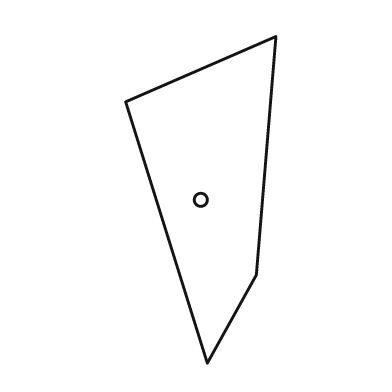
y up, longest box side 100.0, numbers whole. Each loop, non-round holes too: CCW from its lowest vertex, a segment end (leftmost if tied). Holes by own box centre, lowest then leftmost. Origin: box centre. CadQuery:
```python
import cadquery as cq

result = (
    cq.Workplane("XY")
    .moveTo(2.0, -50.0)
    .lineTo(17.0, -23.0)
    .lineTo(23.0, 50.0)
    .lineTo(-23.0, 30.0)
    .close()
    .moveTo(0.0, 0.0)
    .circle(2.0)
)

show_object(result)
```